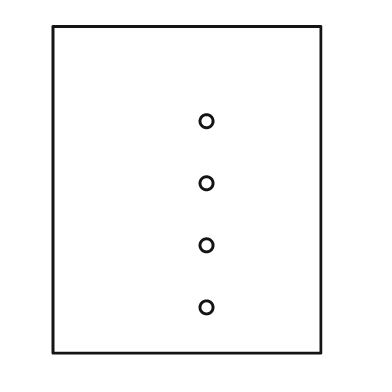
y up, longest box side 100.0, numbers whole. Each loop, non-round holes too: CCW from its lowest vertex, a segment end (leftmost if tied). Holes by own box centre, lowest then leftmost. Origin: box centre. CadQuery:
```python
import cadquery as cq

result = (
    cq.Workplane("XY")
    .moveTo(-41.0, -50.0)
    .lineTo(41.0, -50.0)
    .lineTo(41.0, 50.0)
    .lineTo(-41.0, 50.0)
    .close()
    .moveTo(6.0, -36.0)
    .circle(2.0)
    .moveTo(6.0, -17.0)
    .circle(2.0)
    .moveTo(6.0, 2.0)
    .circle(2.0)
    .moveTo(6.0, 21.0)
    .circle(2.0)
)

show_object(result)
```